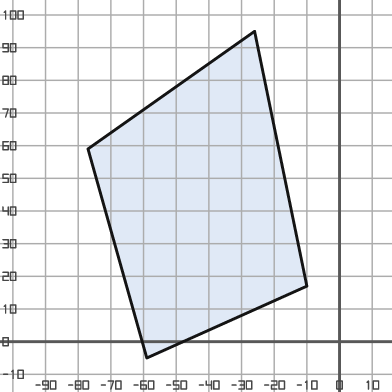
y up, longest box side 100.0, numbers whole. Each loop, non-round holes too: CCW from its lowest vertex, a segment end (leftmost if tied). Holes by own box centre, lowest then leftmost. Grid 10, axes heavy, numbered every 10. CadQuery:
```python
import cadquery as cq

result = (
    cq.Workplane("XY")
    .moveTo(-59.0, -5.0)
    .lineTo(-10.0, 17.0)
    .lineTo(-26.0, 95.0)
    .lineTo(-77.0, 59.0)
    .close()
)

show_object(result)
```